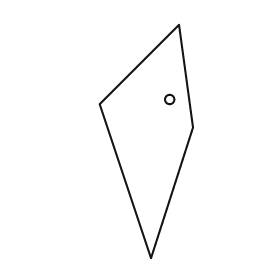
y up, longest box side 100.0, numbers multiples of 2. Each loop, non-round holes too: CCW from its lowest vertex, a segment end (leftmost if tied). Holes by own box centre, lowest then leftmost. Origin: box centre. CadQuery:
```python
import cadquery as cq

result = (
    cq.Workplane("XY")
    .moveTo(2.0, -50.0)
    .lineTo(20.0, 6.0)
    .lineTo(14.0, 50.0)
    .lineTo(-20.0, 16.0)
    .close()
    .moveTo(10.0, 18.0)
    .circle(2.0)
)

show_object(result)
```